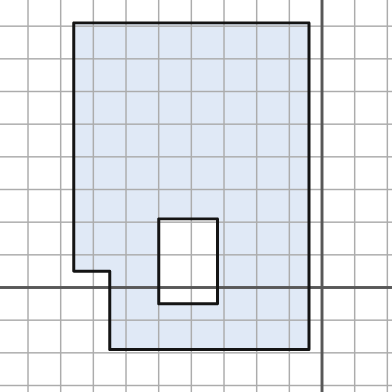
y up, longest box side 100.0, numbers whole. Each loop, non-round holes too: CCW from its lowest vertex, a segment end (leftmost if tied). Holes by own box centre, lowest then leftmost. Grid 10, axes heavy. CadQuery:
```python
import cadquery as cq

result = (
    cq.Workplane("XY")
    .moveTo(-65.0, -19.0)
    .lineTo(-4.0, -19.0)
    .lineTo(-4.0, 81.0)
    .lineTo(-76.0, 81.0)
    .lineTo(-76.0, 5.0)
    .lineTo(-65.0, 5.0)
    .close()
    .moveTo(-50.0, -5.0)
    .lineTo(-32.0, -5.0)
    .lineTo(-32.0, 21.0)
    .lineTo(-50.0, 21.0)
    .close()
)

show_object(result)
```